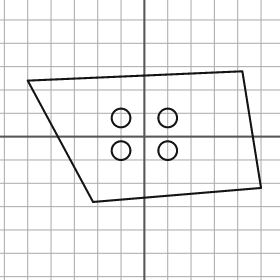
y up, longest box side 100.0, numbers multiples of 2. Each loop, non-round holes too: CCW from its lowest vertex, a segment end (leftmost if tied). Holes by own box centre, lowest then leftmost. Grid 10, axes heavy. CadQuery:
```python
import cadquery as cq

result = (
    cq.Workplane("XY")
    .moveTo(-22.0, -28.0)
    .lineTo(50.0, -22.0)
    .lineTo(42.0, 28.0)
    .lineTo(-50.0, 24.0)
    .close()
    .moveTo(-10.0, -6.0)
    .circle(4.0)
    .moveTo(10.0, -6.0)
    .circle(4.0)
    .moveTo(-10.0, 8.0)
    .circle(4.0)
    .moveTo(10.0, 8.0)
    .circle(4.0)
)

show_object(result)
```